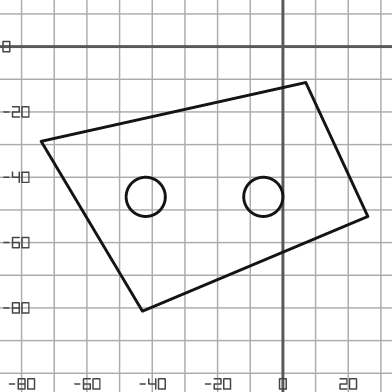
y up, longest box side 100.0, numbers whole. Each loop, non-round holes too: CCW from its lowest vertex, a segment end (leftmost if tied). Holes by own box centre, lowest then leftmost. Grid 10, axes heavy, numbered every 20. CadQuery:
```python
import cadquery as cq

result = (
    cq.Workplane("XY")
    .moveTo(-43.0, -81.0)
    .lineTo(26.0, -52.0)
    .lineTo(7.0, -11.0)
    .lineTo(-74.0, -29.0)
    .close()
    .moveTo(-42.0, -46.0)
    .circle(6.0)
    .moveTo(-6.0, -46.0)
    .circle(6.0)
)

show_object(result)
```